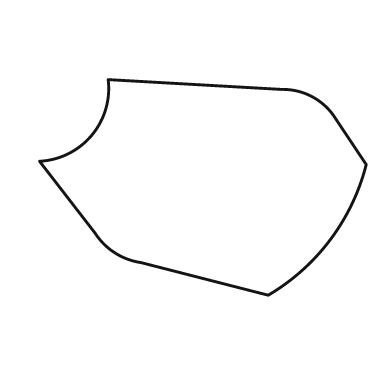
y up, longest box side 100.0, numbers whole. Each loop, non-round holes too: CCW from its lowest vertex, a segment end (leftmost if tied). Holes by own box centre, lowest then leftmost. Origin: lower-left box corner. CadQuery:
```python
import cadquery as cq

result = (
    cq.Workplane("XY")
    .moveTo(70.0, 0.0)
    .threePointArc((89.0, 17.0), (100.0, 40.0))
    .lineTo(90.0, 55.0)
    .threePointArc((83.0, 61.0), (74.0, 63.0))
    .lineTo(21.0, 66.0)
    .threePointArc((16.0, 49.0), (0.0, 41.0))
    .lineTo(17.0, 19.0)
    .threePointArc((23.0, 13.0), (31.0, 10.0))
    .close()
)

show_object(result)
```